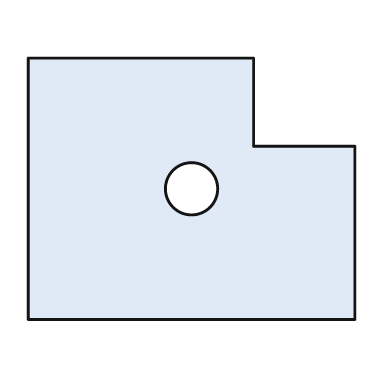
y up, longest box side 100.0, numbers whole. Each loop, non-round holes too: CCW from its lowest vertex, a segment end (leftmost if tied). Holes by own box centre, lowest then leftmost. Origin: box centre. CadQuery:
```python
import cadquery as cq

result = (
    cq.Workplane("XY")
    .moveTo(-50.0, -40.0)
    .lineTo(50.0, -40.0)
    .lineTo(50.0, 13.0)
    .lineTo(19.0, 13.0)
    .lineTo(19.0, 40.0)
    .lineTo(-50.0, 40.0)
    .close()
    .moveTo(0.0, 0.0)
    .circle(8.0)
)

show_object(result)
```